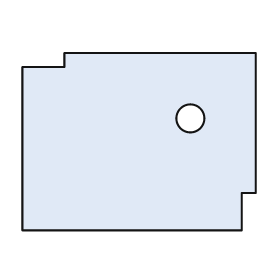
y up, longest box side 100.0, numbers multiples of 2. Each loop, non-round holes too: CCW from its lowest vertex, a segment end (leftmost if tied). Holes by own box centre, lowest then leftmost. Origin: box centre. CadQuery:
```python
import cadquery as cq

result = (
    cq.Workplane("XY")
    .moveTo(-50.0, -38.0)
    .lineTo(44.0, -38.0)
    .lineTo(44.0, -22.0)
    .lineTo(50.0, -22.0)
    .lineTo(50.0, 38.0)
    .lineTo(-32.0, 38.0)
    .lineTo(-32.0, 32.0)
    .lineTo(-50.0, 32.0)
    .close()
    .moveTo(22.0, 10.0)
    .circle(6.0)
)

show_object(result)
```